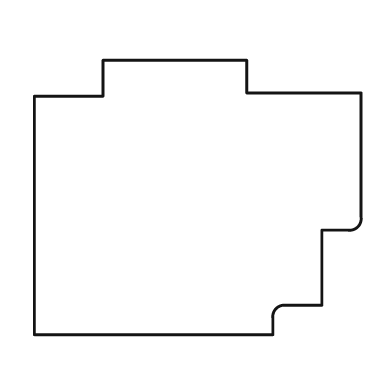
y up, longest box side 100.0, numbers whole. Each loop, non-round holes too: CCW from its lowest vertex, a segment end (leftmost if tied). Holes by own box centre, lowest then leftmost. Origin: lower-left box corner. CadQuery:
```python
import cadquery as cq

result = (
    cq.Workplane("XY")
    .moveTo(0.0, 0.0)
    .lineTo(73.0, 0.0)
    .lineTo(73.0, 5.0)
    .threePointArc((74.0, 8.0), (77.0, 9.0))
    .lineTo(88.0, 9.0)
    .lineTo(88.0, 32.0)
    .lineTo(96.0, 32.0)
    .threePointArc((99.0, 33.0), (100.0, 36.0))
    .lineTo(100.0, 74.0)
    .lineTo(65.0, 74.0)
    .lineTo(65.0, 84.0)
    .lineTo(21.0, 84.0)
    .lineTo(21.0, 73.0)
    .lineTo(0.0, 73.0)
    .close()
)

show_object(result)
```